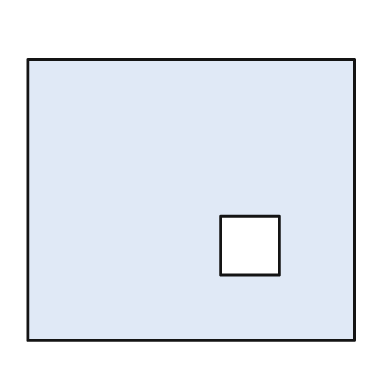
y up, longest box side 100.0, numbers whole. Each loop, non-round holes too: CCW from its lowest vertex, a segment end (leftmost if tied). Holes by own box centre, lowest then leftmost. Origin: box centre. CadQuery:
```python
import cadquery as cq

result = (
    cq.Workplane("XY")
    .moveTo(-50.0, -43.0)
    .lineTo(50.0, -43.0)
    .lineTo(50.0, 43.0)
    .lineTo(-50.0, 43.0)
    .close()
    .moveTo(9.0, -23.0)
    .lineTo(27.0, -23.0)
    .lineTo(27.0, -5.0)
    .lineTo(9.0, -5.0)
    .close()
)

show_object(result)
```